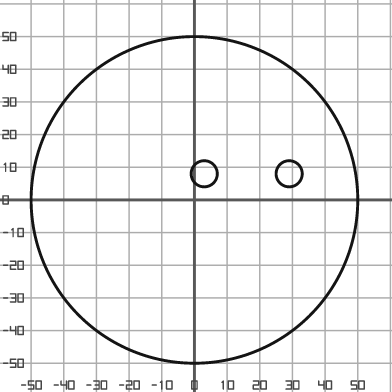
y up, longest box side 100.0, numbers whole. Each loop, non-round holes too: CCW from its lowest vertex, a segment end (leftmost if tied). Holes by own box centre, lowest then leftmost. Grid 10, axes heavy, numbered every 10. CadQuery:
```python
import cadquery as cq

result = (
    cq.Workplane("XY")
    .moveTo(0.0, 0.0)
    .circle(50.0)
    .moveTo(3.0, 8.0)
    .circle(4.0)
    .moveTo(29.0, 8.0)
    .circle(4.0)
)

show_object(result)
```